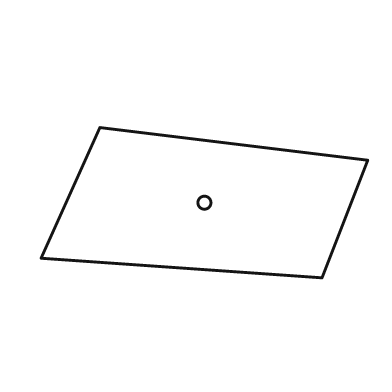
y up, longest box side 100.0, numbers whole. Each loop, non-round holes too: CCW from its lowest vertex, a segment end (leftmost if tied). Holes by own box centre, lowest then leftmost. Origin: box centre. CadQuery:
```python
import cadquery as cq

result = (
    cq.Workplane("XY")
    .moveTo(36.0, -23.0)
    .lineTo(50.0, 13.0)
    .lineTo(-32.0, 23.0)
    .lineTo(-50.0, -17.0)
    .close()
    .moveTo(0.0, 0.0)
    .circle(2.0)
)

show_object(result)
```